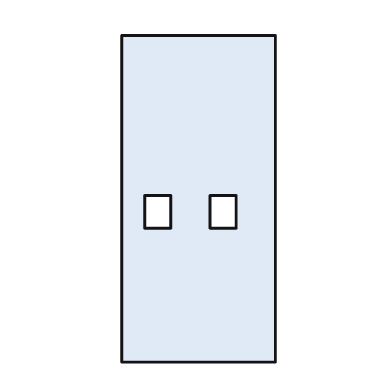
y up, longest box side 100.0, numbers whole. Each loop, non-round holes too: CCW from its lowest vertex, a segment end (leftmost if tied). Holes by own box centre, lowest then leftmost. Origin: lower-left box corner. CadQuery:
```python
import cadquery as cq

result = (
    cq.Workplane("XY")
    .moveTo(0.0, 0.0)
    .lineTo(47.0, 0.0)
    .lineTo(47.0, 100.0)
    .lineTo(0.0, 100.0)
    .close()
    .moveTo(7.0, 41.0)
    .lineTo(15.0, 41.0)
    .lineTo(15.0, 51.0)
    .lineTo(7.0, 51.0)
    .close()
    .moveTo(27.0, 41.0)
    .lineTo(35.0, 41.0)
    .lineTo(35.0, 51.0)
    .lineTo(27.0, 51.0)
    .close()
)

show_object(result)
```